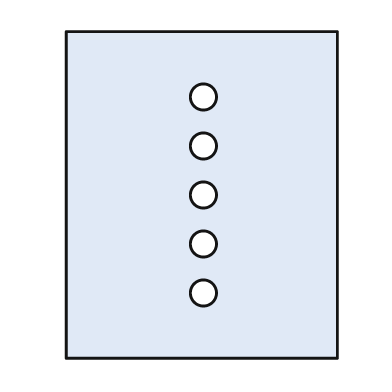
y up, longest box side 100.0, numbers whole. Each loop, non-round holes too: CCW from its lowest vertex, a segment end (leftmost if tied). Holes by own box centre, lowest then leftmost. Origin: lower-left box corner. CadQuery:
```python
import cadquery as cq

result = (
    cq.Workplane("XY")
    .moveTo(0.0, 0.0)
    .lineTo(83.0, 0.0)
    .lineTo(83.0, 100.0)
    .lineTo(0.0, 100.0)
    .close()
    .moveTo(42.0, 20.0)
    .circle(4.0)
    .moveTo(42.0, 35.0)
    .circle(4.0)
    .moveTo(42.0, 50.0)
    .circle(4.0)
    .moveTo(42.0, 65.0)
    .circle(4.0)
    .moveTo(42.0, 80.0)
    .circle(4.0)
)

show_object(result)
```